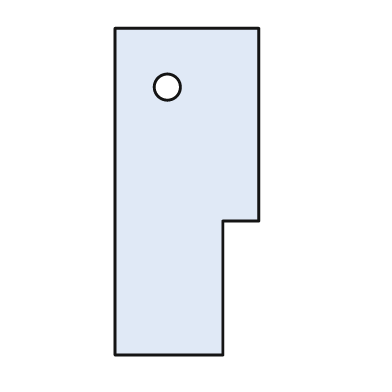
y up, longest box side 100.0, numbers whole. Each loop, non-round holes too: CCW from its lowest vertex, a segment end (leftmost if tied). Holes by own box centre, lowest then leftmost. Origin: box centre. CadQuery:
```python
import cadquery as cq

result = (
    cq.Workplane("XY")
    .moveTo(-22.0, -50.0)
    .lineTo(11.0, -50.0)
    .lineTo(11.0, -9.0)
    .lineTo(22.0, -9.0)
    .lineTo(22.0, 50.0)
    .lineTo(-22.0, 50.0)
    .close()
    .moveTo(-6.0, 32.0)
    .circle(4.0)
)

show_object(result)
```